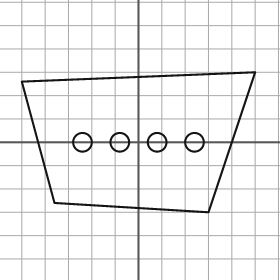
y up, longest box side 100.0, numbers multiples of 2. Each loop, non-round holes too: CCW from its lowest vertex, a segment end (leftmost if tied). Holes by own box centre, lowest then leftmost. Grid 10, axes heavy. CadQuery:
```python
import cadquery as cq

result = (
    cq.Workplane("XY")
    .moveTo(30.0, -30.0)
    .lineTo(50.0, 30.0)
    .lineTo(-50.0, 26.0)
    .lineTo(-36.0, -26.0)
    .close()
    .moveTo(-24.0, 0.0)
    .circle(4.0)
    .moveTo(-8.0, 0.0)
    .circle(4.0)
    .moveTo(8.0, 0.0)
    .circle(4.0)
    .moveTo(24.0, 0.0)
    .circle(4.0)
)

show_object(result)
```